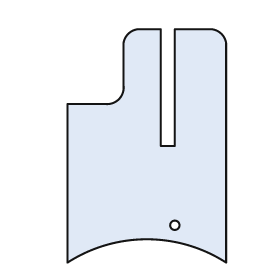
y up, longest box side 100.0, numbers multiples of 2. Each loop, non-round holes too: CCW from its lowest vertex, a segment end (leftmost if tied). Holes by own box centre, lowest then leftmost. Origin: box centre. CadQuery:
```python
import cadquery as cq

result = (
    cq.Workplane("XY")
    .moveTo(-34.0, -50.0)
    .threePointArc((0.0, -40.0), (34.0, -50.0))
    .lineTo(34.0, 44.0)
    .threePointArc((32.0, 48.0), (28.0, 50.0))
    .lineTo(12.0, 50.0)
    .lineTo(12.0, 0.0)
    .lineTo(6.0, 0.0)
    .lineTo(6.0, 50.0)
    .lineTo(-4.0, 50.0)
    .threePointArc((-8.0, 48.0), (-10.0, 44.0))
    .lineTo(-10.0, 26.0)
    .threePointArc((-12.0, 20.0), (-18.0, 18.0))
    .lineTo(-34.0, 18.0)
    .close()
    .moveTo(12.0, -34.0)
    .circle(2.0)
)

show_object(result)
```